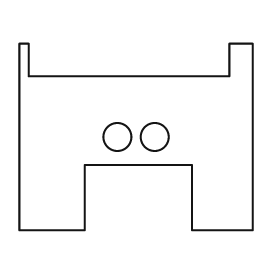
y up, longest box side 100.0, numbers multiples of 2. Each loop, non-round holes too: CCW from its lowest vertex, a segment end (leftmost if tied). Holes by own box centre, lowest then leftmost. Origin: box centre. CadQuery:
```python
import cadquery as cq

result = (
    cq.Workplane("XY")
    .moveTo(-50.0, -40.0)
    .lineTo(-22.0, -40.0)
    .lineTo(-22.0, -12.0)
    .lineTo(24.0, -12.0)
    .lineTo(24.0, -40.0)
    .lineTo(50.0, -40.0)
    .lineTo(50.0, 40.0)
    .lineTo(40.0, 40.0)
    .lineTo(40.0, 26.0)
    .lineTo(-46.0, 26.0)
    .lineTo(-46.0, 40.0)
    .lineTo(-50.0, 40.0)
    .close()
    .moveTo(-8.0, 0.0)
    .circle(6.0)
    .moveTo(8.0, 0.0)
    .circle(6.0)
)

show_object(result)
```